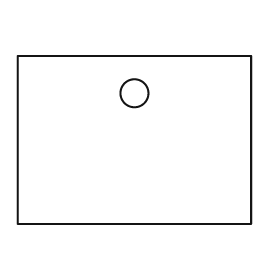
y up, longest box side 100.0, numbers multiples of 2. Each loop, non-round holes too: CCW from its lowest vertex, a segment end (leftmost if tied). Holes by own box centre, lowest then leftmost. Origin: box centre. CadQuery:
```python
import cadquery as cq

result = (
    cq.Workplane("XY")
    .moveTo(-50.0, -36.0)
    .lineTo(50.0, -36.0)
    .lineTo(50.0, 36.0)
    .lineTo(-50.0, 36.0)
    .close()
    .moveTo(0.0, 20.0)
    .circle(6.0)
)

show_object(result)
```